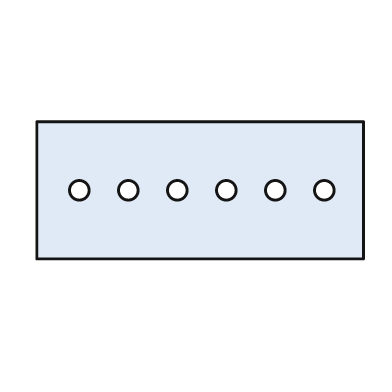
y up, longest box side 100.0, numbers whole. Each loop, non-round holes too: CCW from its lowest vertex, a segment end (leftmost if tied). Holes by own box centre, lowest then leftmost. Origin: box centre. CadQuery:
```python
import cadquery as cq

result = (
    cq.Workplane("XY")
    .moveTo(-50.0, -21.0)
    .lineTo(50.0, -21.0)
    .lineTo(50.0, 21.0)
    .lineTo(-50.0, 21.0)
    .close()
    .moveTo(-37.0, 0.0)
    .circle(3.0)
    .moveTo(-22.0, 0.0)
    .circle(3.0)
    .moveTo(-7.0, 0.0)
    .circle(3.0)
    .moveTo(8.0, 0.0)
    .circle(3.0)
    .moveTo(23.0, 0.0)
    .circle(3.0)
    .moveTo(38.0, 0.0)
    .circle(3.0)
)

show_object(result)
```